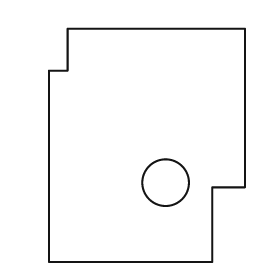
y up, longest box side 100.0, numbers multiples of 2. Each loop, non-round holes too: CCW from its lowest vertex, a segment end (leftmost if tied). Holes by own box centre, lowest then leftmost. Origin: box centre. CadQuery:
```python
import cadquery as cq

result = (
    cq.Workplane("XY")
    .moveTo(-42.0, -50.0)
    .lineTo(28.0, -50.0)
    .lineTo(28.0, -18.0)
    .lineTo(42.0, -18.0)
    .lineTo(42.0, 50.0)
    .lineTo(-34.0, 50.0)
    .lineTo(-34.0, 32.0)
    .lineTo(-42.0, 32.0)
    .close()
    .moveTo(8.0, -16.0)
    .circle(10.0)
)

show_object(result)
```